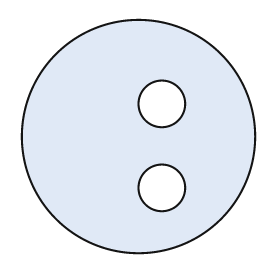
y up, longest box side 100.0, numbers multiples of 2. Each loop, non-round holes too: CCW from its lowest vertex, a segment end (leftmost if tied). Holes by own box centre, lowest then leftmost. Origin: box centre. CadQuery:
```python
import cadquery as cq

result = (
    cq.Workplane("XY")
    .moveTo(0.0, 0.0)
    .circle(50.0)
    .moveTo(10.0, -22.0)
    .circle(10.0)
    .moveTo(10.0, 14.0)
    .circle(10.0)
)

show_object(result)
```